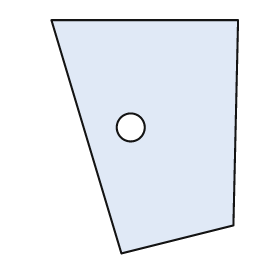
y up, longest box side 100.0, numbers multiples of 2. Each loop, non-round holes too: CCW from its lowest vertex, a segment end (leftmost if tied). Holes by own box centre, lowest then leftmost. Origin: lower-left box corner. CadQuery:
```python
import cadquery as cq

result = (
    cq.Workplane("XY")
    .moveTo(30.0, 0.0)
    .lineTo(78.0, 12.0)
    .lineTo(80.0, 100.0)
    .lineTo(0.0, 100.0)
    .close()
    .moveTo(34.0, 54.0)
    .circle(6.0)
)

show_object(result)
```